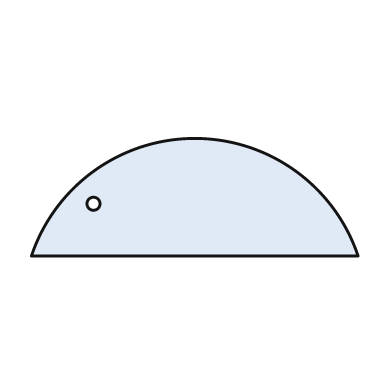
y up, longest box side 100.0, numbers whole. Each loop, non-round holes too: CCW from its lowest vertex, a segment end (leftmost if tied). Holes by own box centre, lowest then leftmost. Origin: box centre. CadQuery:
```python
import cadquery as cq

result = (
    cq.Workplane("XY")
    .moveTo(-50.0, -18.0)
    .lineTo(50.0, -18.0)
    .threePointArc((0.0, 18.0), (-50.0, -18.0))
    .close()
    .moveTo(-31.0, -2.0)
    .circle(2.0)
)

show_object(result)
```